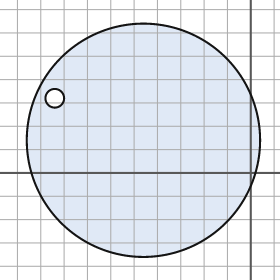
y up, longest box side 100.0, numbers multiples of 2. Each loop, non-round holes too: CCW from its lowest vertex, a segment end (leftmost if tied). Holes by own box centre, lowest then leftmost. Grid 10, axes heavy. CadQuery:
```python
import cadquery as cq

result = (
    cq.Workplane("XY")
    .moveTo(-46.0, 14.0)
    .circle(50.0)
    .moveTo(-84.0, 32.0)
    .circle(4.0)
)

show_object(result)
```